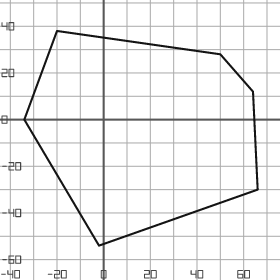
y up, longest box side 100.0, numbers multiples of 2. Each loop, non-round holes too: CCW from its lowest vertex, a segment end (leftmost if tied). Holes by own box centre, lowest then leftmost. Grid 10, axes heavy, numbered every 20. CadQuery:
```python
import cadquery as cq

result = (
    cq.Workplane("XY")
    .moveTo(-2.0, -54.0)
    .lineTo(66.0, -30.0)
    .lineTo(64.0, 12.0)
    .lineTo(50.0, 28.0)
    .lineTo(-20.0, 38.0)
    .lineTo(-34.0, 0.0)
    .close()
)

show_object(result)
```